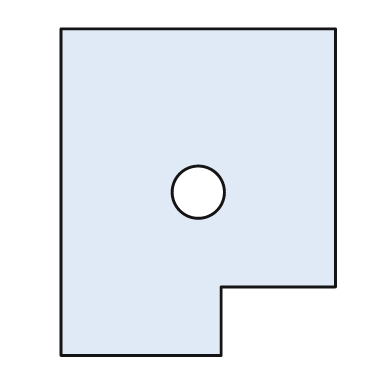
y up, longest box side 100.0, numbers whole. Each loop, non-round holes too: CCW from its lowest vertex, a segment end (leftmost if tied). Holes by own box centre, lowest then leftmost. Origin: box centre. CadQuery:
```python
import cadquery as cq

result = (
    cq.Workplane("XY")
    .moveTo(-42.0, -50.0)
    .lineTo(7.0, -50.0)
    .lineTo(7.0, -29.0)
    .lineTo(42.0, -29.0)
    .lineTo(42.0, 50.0)
    .lineTo(-42.0, 50.0)
    .close()
    .moveTo(0.0, 0.0)
    .circle(8.0)
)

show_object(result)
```